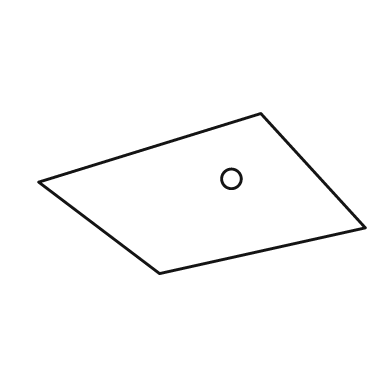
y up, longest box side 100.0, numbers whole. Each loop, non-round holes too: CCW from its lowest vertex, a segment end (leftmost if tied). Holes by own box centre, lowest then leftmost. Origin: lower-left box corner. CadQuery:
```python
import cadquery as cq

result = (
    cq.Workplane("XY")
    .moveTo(37.0, 0.0)
    .lineTo(100.0, 14.0)
    .lineTo(68.0, 49.0)
    .lineTo(0.0, 28.0)
    .close()
    .moveTo(59.0, 29.0)
    .circle(3.0)
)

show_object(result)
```